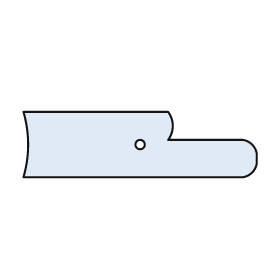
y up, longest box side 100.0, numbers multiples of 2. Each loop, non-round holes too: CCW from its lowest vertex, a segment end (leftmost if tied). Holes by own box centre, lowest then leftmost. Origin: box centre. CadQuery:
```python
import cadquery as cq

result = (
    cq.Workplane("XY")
    .moveTo(-50.0, -14.0)
    .lineTo(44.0, -14.0)
    .threePointArc((48.0, -12.0), (50.0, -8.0))
    .lineTo(50.0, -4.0)
    .threePointArc((48.0, 0.0), (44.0, 2.0))
    .lineTo(12.0, 2.0)
    .threePointArc((14.0, 8.0), (12.0, 14.0))
    .lineTo(-50.0, 14.0)
    .threePointArc((-48.0, 0.0), (-50.0, -14.0))
    .close()
    .moveTo(0.0, 0.0)
    .circle(2.0)
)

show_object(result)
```